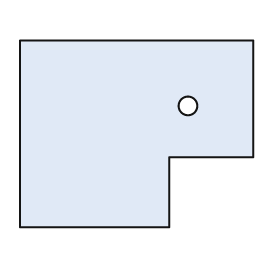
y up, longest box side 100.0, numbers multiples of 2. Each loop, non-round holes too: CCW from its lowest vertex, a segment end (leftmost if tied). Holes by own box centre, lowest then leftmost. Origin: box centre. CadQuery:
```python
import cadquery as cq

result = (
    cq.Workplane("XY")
    .moveTo(-50.0, -40.0)
    .lineTo(14.0, -40.0)
    .lineTo(14.0, -10.0)
    .lineTo(50.0, -10.0)
    .lineTo(50.0, 40.0)
    .lineTo(-50.0, 40.0)
    .close()
    .moveTo(22.0, 12.0)
    .circle(4.0)
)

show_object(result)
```